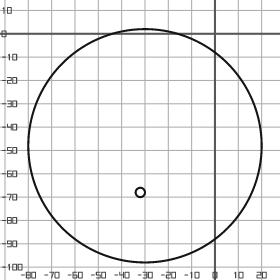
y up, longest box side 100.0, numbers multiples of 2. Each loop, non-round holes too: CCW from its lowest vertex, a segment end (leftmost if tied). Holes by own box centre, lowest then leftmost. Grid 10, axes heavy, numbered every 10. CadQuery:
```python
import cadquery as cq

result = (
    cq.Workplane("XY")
    .moveTo(-30.0, -48.0)
    .circle(50.0)
    .moveTo(-32.0, -68.0)
    .circle(2.0)
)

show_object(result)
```